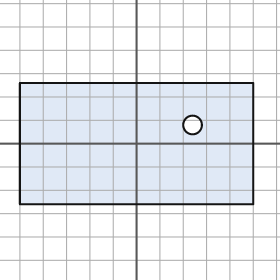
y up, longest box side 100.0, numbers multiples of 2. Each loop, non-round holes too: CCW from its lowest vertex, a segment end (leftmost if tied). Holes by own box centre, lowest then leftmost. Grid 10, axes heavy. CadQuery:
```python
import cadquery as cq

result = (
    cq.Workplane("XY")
    .moveTo(-50.0, -26.0)
    .lineTo(50.0, -26.0)
    .lineTo(50.0, 26.0)
    .lineTo(-50.0, 26.0)
    .close()
    .moveTo(24.0, 8.0)
    .circle(4.0)
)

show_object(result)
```